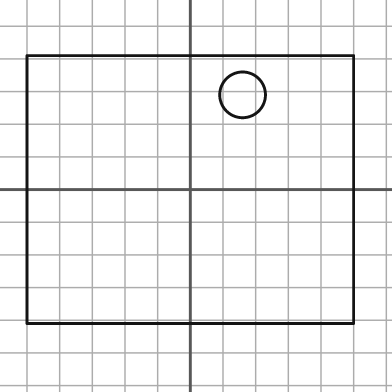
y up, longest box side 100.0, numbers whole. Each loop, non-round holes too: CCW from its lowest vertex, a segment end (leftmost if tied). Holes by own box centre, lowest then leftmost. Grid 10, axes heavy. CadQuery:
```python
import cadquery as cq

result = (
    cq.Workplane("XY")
    .moveTo(-50.0, -41.0)
    .lineTo(50.0, -41.0)
    .lineTo(50.0, 41.0)
    .lineTo(-50.0, 41.0)
    .close()
    .moveTo(16.0, 29.0)
    .circle(7.0)
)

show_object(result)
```